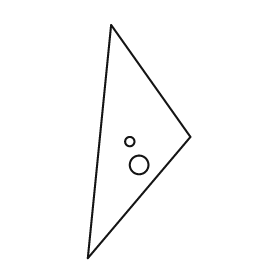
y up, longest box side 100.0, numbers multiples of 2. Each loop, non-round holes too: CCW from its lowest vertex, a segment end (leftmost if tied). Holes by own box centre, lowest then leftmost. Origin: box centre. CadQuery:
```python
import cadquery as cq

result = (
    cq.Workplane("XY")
    .moveTo(-22.0, -50.0)
    .lineTo(22.0, 2.0)
    .lineTo(-12.0, 50.0)
    .close()
    .moveTo(0.0, -10.0)
    .circle(4.0)
    .moveTo(-4.0, 0.0)
    .circle(2.0)
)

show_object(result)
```